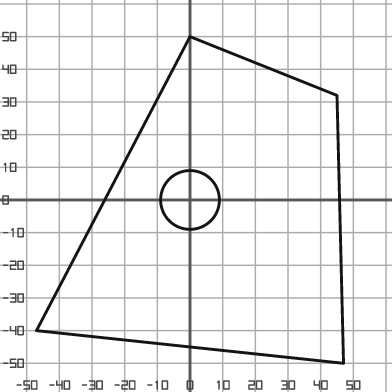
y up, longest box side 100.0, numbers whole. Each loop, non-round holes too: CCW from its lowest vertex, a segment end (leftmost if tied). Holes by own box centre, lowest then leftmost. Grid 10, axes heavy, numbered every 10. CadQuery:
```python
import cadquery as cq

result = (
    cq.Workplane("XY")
    .moveTo(47.0, -50.0)
    .lineTo(45.0, 32.0)
    .lineTo(0.0, 50.0)
    .lineTo(-47.0, -40.0)
    .close()
    .moveTo(0.0, 0.0)
    .circle(9.0)
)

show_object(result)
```